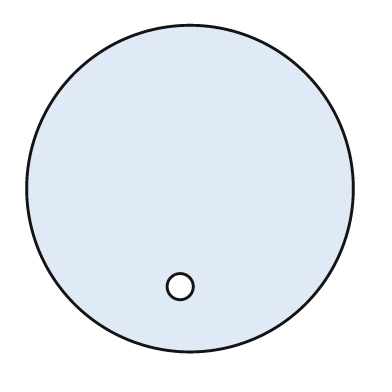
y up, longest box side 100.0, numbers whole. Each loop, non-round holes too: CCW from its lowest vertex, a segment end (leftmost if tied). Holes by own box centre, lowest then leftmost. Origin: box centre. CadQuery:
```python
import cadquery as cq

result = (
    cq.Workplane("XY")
    .moveTo(0.0, 0.0)
    .circle(50.0)
    .moveTo(-3.0, -30.0)
    .circle(4.0)
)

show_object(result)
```